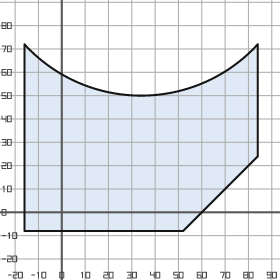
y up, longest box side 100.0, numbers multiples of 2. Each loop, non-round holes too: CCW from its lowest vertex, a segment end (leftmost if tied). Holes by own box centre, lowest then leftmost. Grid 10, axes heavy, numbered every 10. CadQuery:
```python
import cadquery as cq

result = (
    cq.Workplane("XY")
    .moveTo(-16.0, -8.0)
    .lineTo(52.0, -8.0)
    .lineTo(84.0, 24.0)
    .lineTo(84.0, 72.0)
    .threePointArc((34.0, 50.0), (-16.0, 72.0))
    .close()
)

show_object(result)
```